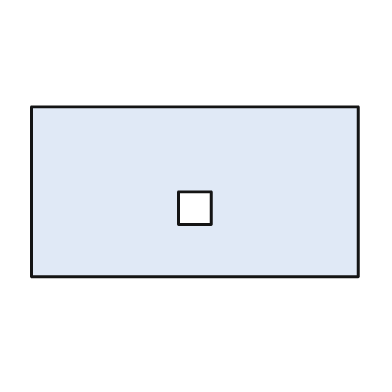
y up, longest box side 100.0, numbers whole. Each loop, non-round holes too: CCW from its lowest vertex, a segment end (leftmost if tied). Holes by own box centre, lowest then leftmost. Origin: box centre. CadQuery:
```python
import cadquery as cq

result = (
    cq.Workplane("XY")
    .moveTo(-50.0, -26.0)
    .lineTo(50.0, -26.0)
    .lineTo(50.0, 26.0)
    .lineTo(-50.0, 26.0)
    .close()
    .moveTo(-5.0, -10.0)
    .lineTo(5.0, -10.0)
    .lineTo(5.0, 0.0)
    .lineTo(-5.0, 0.0)
    .close()
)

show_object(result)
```